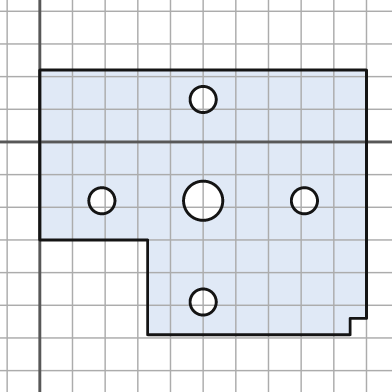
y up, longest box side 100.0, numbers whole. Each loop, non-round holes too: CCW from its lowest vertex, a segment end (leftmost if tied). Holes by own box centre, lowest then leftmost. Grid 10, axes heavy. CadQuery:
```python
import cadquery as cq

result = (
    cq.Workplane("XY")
    .moveTo(33.0, -59.0)
    .lineTo(95.0, -59.0)
    .lineTo(95.0, -54.0)
    .lineTo(100.0, -54.0)
    .lineTo(100.0, 22.0)
    .lineTo(0.0, 22.0)
    .lineTo(0.0, -30.0)
    .lineTo(33.0, -30.0)
    .close()
    .moveTo(50.0, -49.0)
    .circle(4.0)
    .moveTo(19.0, -18.0)
    .circle(4.0)
    .moveTo(50.0, -18.0)
    .circle(6.0)
    .moveTo(81.0, -18.0)
    .circle(4.0)
    .moveTo(50.0, 13.0)
    .circle(4.0)
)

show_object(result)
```